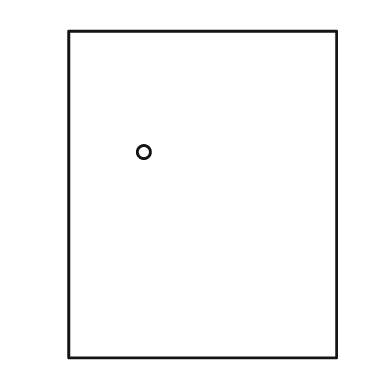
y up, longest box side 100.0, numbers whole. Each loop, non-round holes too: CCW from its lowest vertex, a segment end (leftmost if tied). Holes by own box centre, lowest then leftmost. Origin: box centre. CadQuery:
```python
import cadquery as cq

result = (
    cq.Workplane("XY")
    .moveTo(-41.0, -50.0)
    .lineTo(41.0, -50.0)
    .lineTo(41.0, 50.0)
    .lineTo(-41.0, 50.0)
    .close()
    .moveTo(-18.0, 13.0)
    .circle(2.0)
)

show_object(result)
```